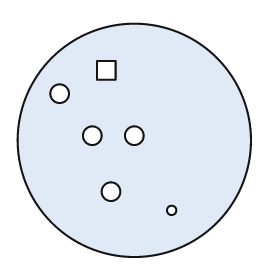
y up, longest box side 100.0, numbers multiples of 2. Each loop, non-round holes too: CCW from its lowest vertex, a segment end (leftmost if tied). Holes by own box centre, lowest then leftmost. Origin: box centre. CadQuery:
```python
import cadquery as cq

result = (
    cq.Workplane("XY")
    .moveTo(0.0, 0.0)
    .circle(50.0)
    .moveTo(16.0, -30.0)
    .circle(2.0)
    .moveTo(-10.0, -22.0)
    .circle(4.0)
    .moveTo(-18.0, 2.0)
    .circle(4.0)
    .moveTo(0.0, 2.0)
    .circle(4.0)
    .moveTo(-32.0, 20.0)
    .circle(4.0)
    .moveTo(-16.0, 26.0)
    .lineTo(-8.0, 26.0)
    .lineTo(-8.0, 34.0)
    .lineTo(-16.0, 34.0)
    .close()
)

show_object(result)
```